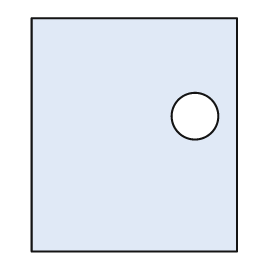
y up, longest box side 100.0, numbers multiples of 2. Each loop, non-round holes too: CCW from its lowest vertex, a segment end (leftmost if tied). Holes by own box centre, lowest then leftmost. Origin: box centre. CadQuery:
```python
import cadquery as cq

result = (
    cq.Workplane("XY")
    .moveTo(-44.0, -50.0)
    .lineTo(44.0, -50.0)
    .lineTo(44.0, 50.0)
    .lineTo(-44.0, 50.0)
    .close()
    .moveTo(26.0, 8.0)
    .circle(10.0)
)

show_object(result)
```